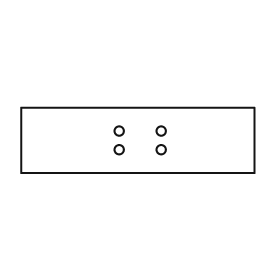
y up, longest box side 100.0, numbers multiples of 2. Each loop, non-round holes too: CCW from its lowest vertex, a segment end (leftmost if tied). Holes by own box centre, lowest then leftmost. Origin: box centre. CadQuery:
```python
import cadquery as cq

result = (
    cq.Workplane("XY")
    .moveTo(-50.0, -14.0)
    .lineTo(50.0, -14.0)
    .lineTo(50.0, 14.0)
    .lineTo(-50.0, 14.0)
    .close()
    .moveTo(-8.0, -4.0)
    .circle(2.0)
    .moveTo(10.0, -4.0)
    .circle(2.0)
    .moveTo(-8.0, 4.0)
    .circle(2.0)
    .moveTo(10.0, 4.0)
    .circle(2.0)
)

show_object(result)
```